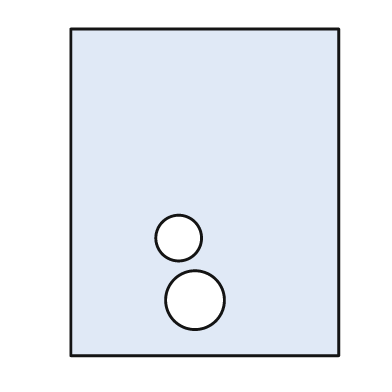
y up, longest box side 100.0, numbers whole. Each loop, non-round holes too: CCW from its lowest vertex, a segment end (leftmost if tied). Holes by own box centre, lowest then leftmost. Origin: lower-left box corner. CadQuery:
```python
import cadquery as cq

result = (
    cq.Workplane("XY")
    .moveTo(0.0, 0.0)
    .lineTo(82.0, 0.0)
    .lineTo(82.0, 100.0)
    .lineTo(0.0, 100.0)
    .close()
    .moveTo(38.0, 17.0)
    .circle(9.0)
    .moveTo(33.0, 36.0)
    .circle(7.0)
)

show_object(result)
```